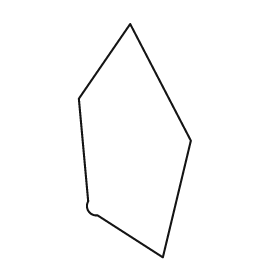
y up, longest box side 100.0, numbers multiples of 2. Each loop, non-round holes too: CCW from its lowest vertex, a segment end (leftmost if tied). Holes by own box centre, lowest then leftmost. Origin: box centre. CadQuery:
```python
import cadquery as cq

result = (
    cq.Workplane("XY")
    .moveTo(12.0, -50.0)
    .lineTo(24.0, 0.0)
    .lineTo(-2.0, 50.0)
    .lineTo(-24.0, 18.0)
    .lineTo(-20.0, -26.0)
    .threePointArc((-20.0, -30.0), (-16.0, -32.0))
    .close()
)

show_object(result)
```